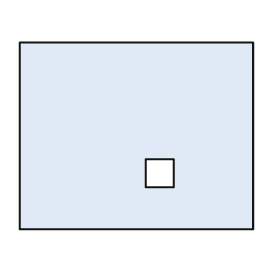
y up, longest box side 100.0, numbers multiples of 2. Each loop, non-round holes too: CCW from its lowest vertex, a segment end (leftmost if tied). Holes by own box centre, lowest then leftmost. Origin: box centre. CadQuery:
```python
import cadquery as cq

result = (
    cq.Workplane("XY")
    .moveTo(-50.0, -40.0)
    .lineTo(50.0, -40.0)
    .lineTo(50.0, 40.0)
    .lineTo(-50.0, 40.0)
    .close()
    .moveTo(4.0, -22.0)
    .lineTo(16.0, -22.0)
    .lineTo(16.0, -10.0)
    .lineTo(4.0, -10.0)
    .close()
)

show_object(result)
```